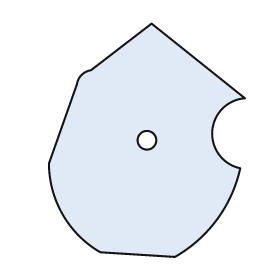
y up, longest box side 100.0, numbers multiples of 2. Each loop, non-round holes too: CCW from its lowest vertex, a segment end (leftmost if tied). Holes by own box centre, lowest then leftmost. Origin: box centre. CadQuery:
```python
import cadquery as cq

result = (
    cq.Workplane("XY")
    .moveTo(12.0, -50.0)
    .threePointArc((30.0, -34.0), (40.0, -12.0))
    .threePointArc((28.0, 4.0), (42.0, 18.0))
    .lineTo(2.0, 50.0)
    .lineTo(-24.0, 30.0)
    .threePointArc((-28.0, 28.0), (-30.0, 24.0))
    .lineTo(-42.0, -10.0)
    .threePointArc((-36.0, -32.0), (-20.0, -48.0))
    .close()
    .moveTo(0.0, 0.0)
    .circle(4.0)
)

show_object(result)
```